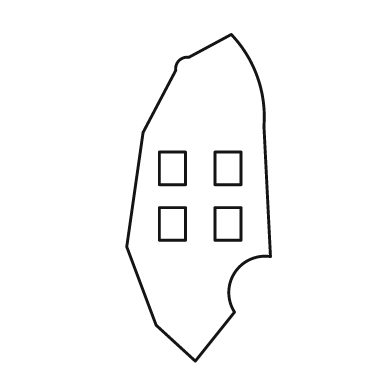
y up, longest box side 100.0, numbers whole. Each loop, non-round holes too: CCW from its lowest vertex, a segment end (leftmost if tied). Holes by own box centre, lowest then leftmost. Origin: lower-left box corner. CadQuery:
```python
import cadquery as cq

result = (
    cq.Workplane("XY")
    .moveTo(21.0, 0.0)
    .lineTo(33.0, 15.0)
    .threePointArc((33.0, 27.0), (44.0, 32.0))
    .lineTo(42.0, 72.0)
    .threePointArc((40.0, 87.0), (32.0, 100.0))
    .lineTo(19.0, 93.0)
    .threePointArc((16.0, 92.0), (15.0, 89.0))
    .lineTo(5.0, 70.0)
    .lineTo(0.0, 35.0)
    .lineTo(9.0, 11.0)
    .close()
    .moveTo(10.0, 37.0)
    .lineTo(18.0, 37.0)
    .lineTo(18.0, 47.0)
    .lineTo(10.0, 47.0)
    .close()
    .moveTo(27.0, 37.0)
    .lineTo(35.0, 37.0)
    .lineTo(35.0, 47.0)
    .lineTo(27.0, 47.0)
    .close()
    .moveTo(10.0, 54.0)
    .lineTo(18.0, 54.0)
    .lineTo(18.0, 64.0)
    .lineTo(10.0, 64.0)
    .close()
    .moveTo(27.0, 54.0)
    .lineTo(35.0, 54.0)
    .lineTo(35.0, 64.0)
    .lineTo(27.0, 64.0)
    .close()
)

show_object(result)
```